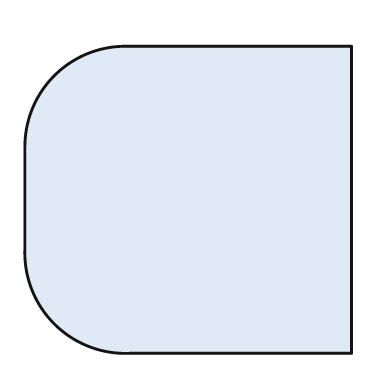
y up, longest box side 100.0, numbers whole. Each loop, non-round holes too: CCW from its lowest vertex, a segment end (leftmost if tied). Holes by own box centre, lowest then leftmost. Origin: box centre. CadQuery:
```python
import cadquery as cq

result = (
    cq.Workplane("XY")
    .moveTo(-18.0, -47.0)
    .lineTo(50.0, -47.0)
    .lineTo(50.0, 47.0)
    .lineTo(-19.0, 47.0)
    .threePointArc((-41.0, 38.0), (-50.0, 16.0))
    .lineTo(-50.0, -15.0)
    .threePointArc((-41.0, -38.0), (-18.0, -47.0))
    .close()
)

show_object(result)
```